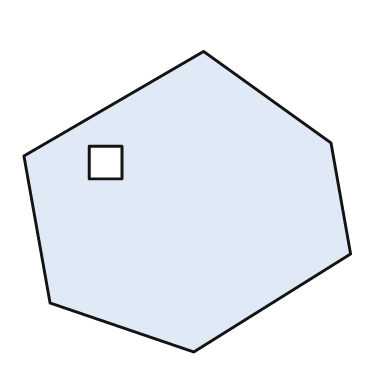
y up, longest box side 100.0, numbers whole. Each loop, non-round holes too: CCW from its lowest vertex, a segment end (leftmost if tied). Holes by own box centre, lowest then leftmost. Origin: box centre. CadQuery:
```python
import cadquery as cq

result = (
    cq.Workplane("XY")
    .moveTo(2.0, -46.0)
    .lineTo(50.0, -16.0)
    .lineTo(44.0, 18.0)
    .lineTo(5.0, 46.0)
    .lineTo(-50.0, 14.0)
    .lineTo(-42.0, -31.0)
    .close()
    .moveTo(-30.0, 7.0)
    .lineTo(-20.0, 7.0)
    .lineTo(-20.0, 17.0)
    .lineTo(-30.0, 17.0)
    .close()
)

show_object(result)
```